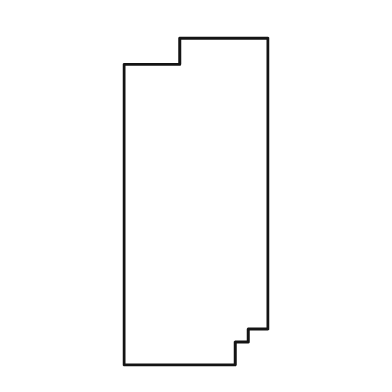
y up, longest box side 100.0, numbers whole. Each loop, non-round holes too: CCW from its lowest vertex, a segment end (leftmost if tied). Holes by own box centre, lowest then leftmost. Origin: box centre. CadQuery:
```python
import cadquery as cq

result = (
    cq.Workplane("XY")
    .moveTo(-22.0, -50.0)
    .lineTo(12.0, -50.0)
    .lineTo(12.0, -43.0)
    .lineTo(16.0, -43.0)
    .lineTo(16.0, -39.0)
    .lineTo(22.0, -39.0)
    .lineTo(22.0, 50.0)
    .lineTo(-5.0, 50.0)
    .lineTo(-5.0, 42.0)
    .lineTo(-22.0, 42.0)
    .close()
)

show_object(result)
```